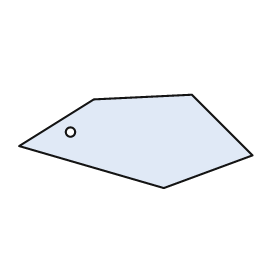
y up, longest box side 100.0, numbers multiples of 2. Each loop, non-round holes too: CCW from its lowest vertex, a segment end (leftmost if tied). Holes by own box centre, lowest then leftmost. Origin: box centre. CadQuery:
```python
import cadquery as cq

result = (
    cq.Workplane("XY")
    .moveTo(12.0, -20.0)
    .lineTo(50.0, -6.0)
    .lineTo(24.0, 20.0)
    .lineTo(-18.0, 18.0)
    .lineTo(-50.0, -2.0)
    .close()
    .moveTo(-28.0, 4.0)
    .circle(2.0)
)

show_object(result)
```